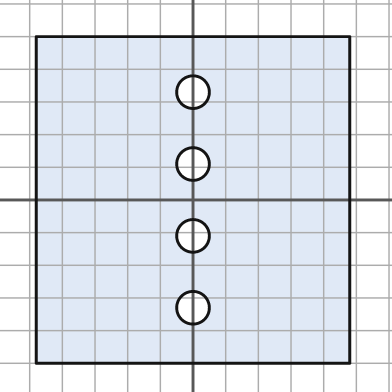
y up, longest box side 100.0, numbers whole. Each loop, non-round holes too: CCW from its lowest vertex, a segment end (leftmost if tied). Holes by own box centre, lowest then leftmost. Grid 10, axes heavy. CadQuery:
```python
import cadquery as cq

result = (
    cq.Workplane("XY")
    .moveTo(-48.0, -50.0)
    .lineTo(48.0, -50.0)
    .lineTo(48.0, 50.0)
    .lineTo(-48.0, 50.0)
    .close()
    .moveTo(0.0, -33.0)
    .circle(5.0)
    .moveTo(0.0, -11.0)
    .circle(5.0)
    .moveTo(0.0, 11.0)
    .circle(5.0)
    .moveTo(0.0, 33.0)
    .circle(5.0)
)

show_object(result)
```